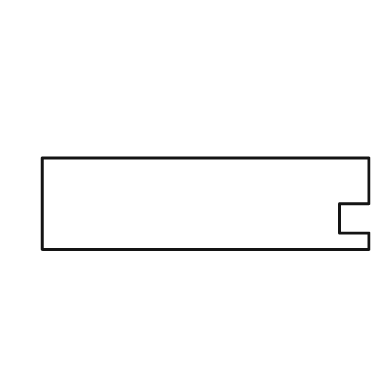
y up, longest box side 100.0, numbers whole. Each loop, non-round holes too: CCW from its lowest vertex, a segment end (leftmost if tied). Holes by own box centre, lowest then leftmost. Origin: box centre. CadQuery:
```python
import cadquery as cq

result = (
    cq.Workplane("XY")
    .moveTo(-50.0, -14.0)
    .lineTo(50.0, -14.0)
    .lineTo(50.0, -9.0)
    .lineTo(41.0, -9.0)
    .lineTo(41.0, 0.0)
    .lineTo(50.0, 0.0)
    .lineTo(50.0, 14.0)
    .lineTo(-50.0, 14.0)
    .close()
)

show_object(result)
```